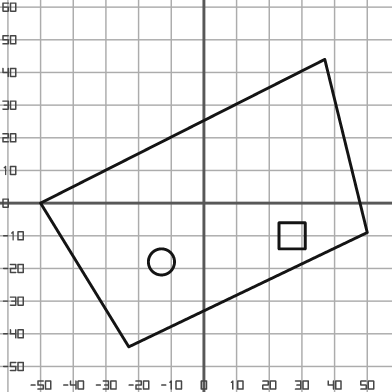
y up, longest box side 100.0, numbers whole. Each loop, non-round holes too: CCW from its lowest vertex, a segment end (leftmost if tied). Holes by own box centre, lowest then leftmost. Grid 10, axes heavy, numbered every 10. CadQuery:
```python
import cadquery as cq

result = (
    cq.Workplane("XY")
    .moveTo(-23.0, -44.0)
    .lineTo(50.0, -9.0)
    .lineTo(37.0, 44.0)
    .lineTo(-50.0, 0.0)
    .close()
    .moveTo(-13.0, -18.0)
    .circle(4.0)
    .moveTo(23.0, -14.0)
    .lineTo(31.0, -14.0)
    .lineTo(31.0, -6.0)
    .lineTo(23.0, -6.0)
    .close()
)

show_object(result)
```